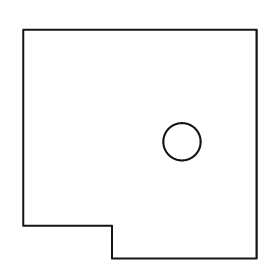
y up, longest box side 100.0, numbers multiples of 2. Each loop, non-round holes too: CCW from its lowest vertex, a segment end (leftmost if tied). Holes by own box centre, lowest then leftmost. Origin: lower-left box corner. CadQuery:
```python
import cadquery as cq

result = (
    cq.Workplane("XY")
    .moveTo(38.0, 0.0)
    .lineTo(100.0, 0.0)
    .lineTo(100.0, 98.0)
    .lineTo(0.0, 98.0)
    .lineTo(0.0, 14.0)
    .lineTo(38.0, 14.0)
    .close()
    .moveTo(68.0, 50.0)
    .circle(8.0)
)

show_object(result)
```